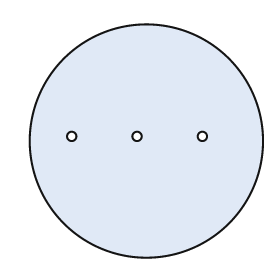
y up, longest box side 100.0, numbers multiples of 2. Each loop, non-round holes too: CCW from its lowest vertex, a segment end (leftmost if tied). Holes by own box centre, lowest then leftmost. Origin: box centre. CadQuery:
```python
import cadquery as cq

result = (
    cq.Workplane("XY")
    .moveTo(0.0, 0.0)
    .circle(50.0)
    .moveTo(-32.0, 2.0)
    .circle(2.0)
    .moveTo(-4.0, 2.0)
    .circle(2.0)
    .moveTo(24.0, 2.0)
    .circle(2.0)
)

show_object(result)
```